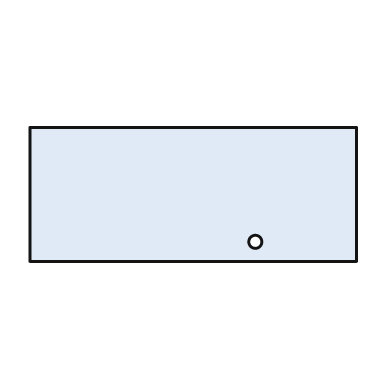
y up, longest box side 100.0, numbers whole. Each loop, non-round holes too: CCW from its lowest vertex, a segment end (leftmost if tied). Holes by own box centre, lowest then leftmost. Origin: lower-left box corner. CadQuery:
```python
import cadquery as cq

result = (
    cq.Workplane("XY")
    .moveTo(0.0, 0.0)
    .lineTo(100.0, 0.0)
    .lineTo(100.0, 41.0)
    .lineTo(0.0, 41.0)
    .close()
    .moveTo(69.0, 6.0)
    .circle(2.0)
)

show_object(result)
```